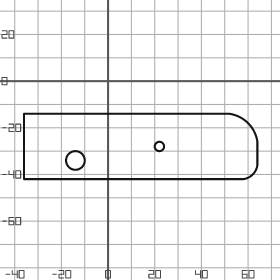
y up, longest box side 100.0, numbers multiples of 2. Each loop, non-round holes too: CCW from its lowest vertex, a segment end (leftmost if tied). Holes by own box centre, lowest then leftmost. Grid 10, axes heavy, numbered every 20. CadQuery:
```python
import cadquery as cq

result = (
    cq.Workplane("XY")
    .moveTo(-36.0, -42.0)
    .lineTo(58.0, -42.0)
    .threePointArc((62.0, -40.0), (64.0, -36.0))
    .lineTo(64.0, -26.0)
    .threePointArc((60.0, -18.0), (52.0, -14.0))
    .lineTo(-36.0, -14.0)
    .close()
    .moveTo(-14.0, -34.0)
    .circle(4.0)
    .moveTo(22.0, -28.0)
    .circle(2.0)
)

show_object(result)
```